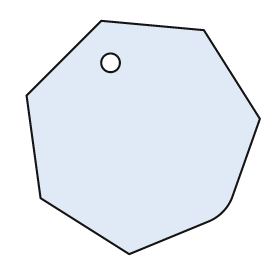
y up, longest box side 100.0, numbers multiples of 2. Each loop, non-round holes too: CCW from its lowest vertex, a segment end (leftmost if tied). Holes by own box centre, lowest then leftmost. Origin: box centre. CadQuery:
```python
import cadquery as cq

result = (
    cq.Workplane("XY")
    .moveTo(-6.0, -50.0)
    .lineTo(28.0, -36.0)
    .threePointArc((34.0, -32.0), (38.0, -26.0))
    .lineTo(50.0, 8.0)
    .lineTo(26.0, 46.0)
    .lineTo(-18.0, 50.0)
    .lineTo(-50.0, 18.0)
    .lineTo(-44.0, -26.0)
    .close()
    .moveTo(-14.0, 32.0)
    .circle(4.0)
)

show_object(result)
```